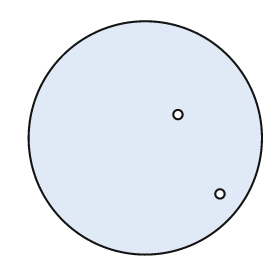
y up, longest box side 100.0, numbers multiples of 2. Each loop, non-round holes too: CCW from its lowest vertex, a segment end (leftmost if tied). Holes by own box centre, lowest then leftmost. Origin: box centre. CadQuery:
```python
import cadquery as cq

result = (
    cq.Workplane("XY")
    .moveTo(0.0, 0.0)
    .circle(50.0)
    .moveTo(32.0, -24.0)
    .circle(2.0)
    .moveTo(14.0, 10.0)
    .circle(2.0)
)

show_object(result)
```